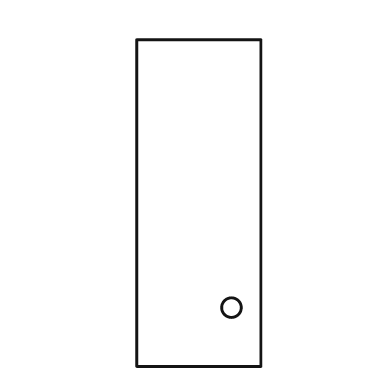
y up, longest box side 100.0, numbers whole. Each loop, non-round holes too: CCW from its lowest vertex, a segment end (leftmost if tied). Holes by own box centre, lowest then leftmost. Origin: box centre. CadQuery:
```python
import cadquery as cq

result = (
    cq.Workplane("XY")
    .moveTo(-19.0, -50.0)
    .lineTo(19.0, -50.0)
    .lineTo(19.0, 50.0)
    .lineTo(-19.0, 50.0)
    .close()
    .moveTo(10.0, -32.0)
    .circle(3.0)
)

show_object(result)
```